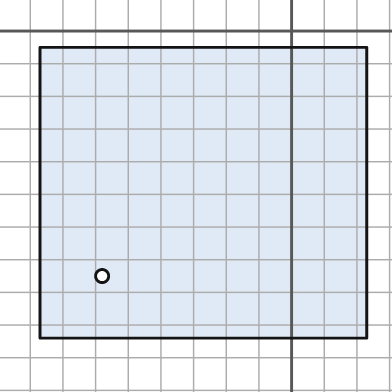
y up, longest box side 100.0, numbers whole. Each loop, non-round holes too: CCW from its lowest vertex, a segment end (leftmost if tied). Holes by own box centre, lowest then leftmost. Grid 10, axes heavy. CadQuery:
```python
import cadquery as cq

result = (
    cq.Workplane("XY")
    .moveTo(-77.0, -94.0)
    .lineTo(23.0, -94.0)
    .lineTo(23.0, -5.0)
    .lineTo(-77.0, -5.0)
    .close()
    .moveTo(-58.0, -75.0)
    .circle(2.0)
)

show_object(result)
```